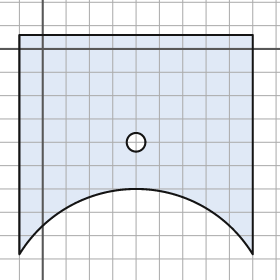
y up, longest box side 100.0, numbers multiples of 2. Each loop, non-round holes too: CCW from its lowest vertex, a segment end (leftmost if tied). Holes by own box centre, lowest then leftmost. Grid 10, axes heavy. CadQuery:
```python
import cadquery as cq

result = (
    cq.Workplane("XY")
    .moveTo(-10.0, -88.0)
    .threePointArc((40.0, -60.0), (90.0, -88.0))
    .lineTo(90.0, 6.0)
    .lineTo(-10.0, 6.0)
    .close()
    .moveTo(40.0, -40.0)
    .circle(4.0)
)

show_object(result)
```